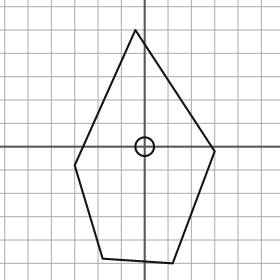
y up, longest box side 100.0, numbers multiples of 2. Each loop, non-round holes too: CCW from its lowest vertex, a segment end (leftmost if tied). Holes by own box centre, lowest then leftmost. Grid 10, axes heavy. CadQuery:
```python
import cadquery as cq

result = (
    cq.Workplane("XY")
    .moveTo(12.0, -50.0)
    .lineTo(30.0, -2.0)
    .lineTo(-4.0, 50.0)
    .lineTo(-30.0, -8.0)
    .lineTo(-18.0, -48.0)
    .close()
    .moveTo(0.0, 0.0)
    .circle(4.0)
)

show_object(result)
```